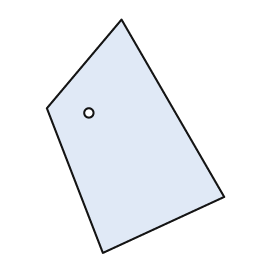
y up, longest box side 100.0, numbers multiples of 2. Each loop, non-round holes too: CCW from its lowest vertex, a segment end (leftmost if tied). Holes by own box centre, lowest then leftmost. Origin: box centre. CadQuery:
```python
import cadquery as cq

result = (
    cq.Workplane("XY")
    .moveTo(-14.0, -50.0)
    .lineTo(38.0, -26.0)
    .lineTo(-6.0, 50.0)
    .lineTo(-38.0, 12.0)
    .close()
    .moveTo(-20.0, 10.0)
    .circle(2.0)
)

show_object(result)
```